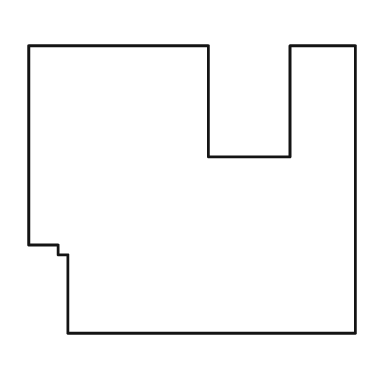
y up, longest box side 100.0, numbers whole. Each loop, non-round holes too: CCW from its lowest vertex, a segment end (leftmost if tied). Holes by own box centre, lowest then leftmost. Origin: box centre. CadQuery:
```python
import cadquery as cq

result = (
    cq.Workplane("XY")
    .moveTo(-38.0, -44.0)
    .lineTo(50.0, -44.0)
    .lineTo(50.0, 44.0)
    .lineTo(30.0, 44.0)
    .lineTo(30.0, 10.0)
    .lineTo(5.0, 10.0)
    .lineTo(5.0, 44.0)
    .lineTo(-50.0, 44.0)
    .lineTo(-50.0, -17.0)
    .lineTo(-41.0, -17.0)
    .lineTo(-41.0, -20.0)
    .lineTo(-38.0, -20.0)
    .close()
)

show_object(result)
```